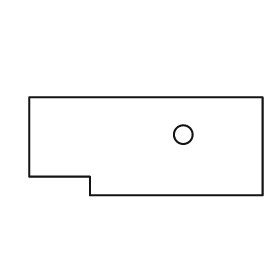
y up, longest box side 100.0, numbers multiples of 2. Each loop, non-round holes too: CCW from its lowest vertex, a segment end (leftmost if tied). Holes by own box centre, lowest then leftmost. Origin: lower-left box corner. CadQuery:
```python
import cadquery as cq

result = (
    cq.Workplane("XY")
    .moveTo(26.0, 0.0)
    .lineTo(100.0, 0.0)
    .lineTo(100.0, 42.0)
    .lineTo(0.0, 42.0)
    .lineTo(0.0, 8.0)
    .lineTo(26.0, 8.0)
    .close()
    .moveTo(66.0, 26.0)
    .circle(4.0)
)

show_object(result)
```